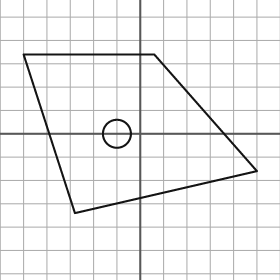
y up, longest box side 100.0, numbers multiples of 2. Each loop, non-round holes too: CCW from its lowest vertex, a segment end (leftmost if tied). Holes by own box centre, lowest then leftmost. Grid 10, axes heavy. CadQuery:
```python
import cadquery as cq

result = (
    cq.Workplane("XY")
    .moveTo(-28.0, -34.0)
    .lineTo(50.0, -16.0)
    .lineTo(6.0, 34.0)
    .lineTo(-50.0, 34.0)
    .close()
    .moveTo(-10.0, 0.0)
    .circle(6.0)
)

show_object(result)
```